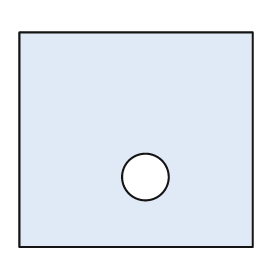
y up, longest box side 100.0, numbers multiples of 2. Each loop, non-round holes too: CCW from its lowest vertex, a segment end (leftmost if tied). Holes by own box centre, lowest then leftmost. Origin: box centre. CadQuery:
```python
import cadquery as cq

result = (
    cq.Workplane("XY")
    .moveTo(-50.0, -46.0)
    .lineTo(50.0, -46.0)
    .lineTo(50.0, 46.0)
    .lineTo(-50.0, 46.0)
    .close()
    .moveTo(4.0, -16.0)
    .circle(10.0)
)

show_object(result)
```